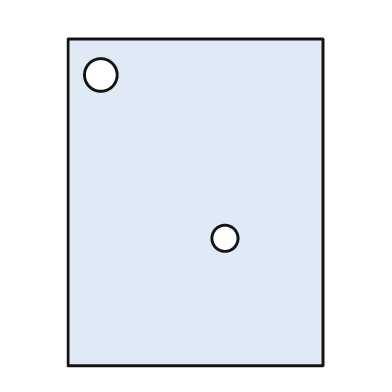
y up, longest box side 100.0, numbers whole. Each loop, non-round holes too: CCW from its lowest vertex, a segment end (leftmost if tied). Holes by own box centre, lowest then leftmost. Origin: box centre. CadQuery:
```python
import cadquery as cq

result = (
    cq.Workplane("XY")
    .moveTo(-39.0, -50.0)
    .lineTo(39.0, -50.0)
    .lineTo(39.0, 50.0)
    .lineTo(-39.0, 50.0)
    .close()
    .moveTo(9.0, -11.0)
    .circle(4.0)
    .moveTo(-29.0, 39.0)
    .circle(5.0)
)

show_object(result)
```